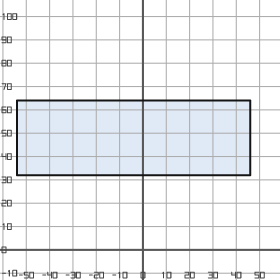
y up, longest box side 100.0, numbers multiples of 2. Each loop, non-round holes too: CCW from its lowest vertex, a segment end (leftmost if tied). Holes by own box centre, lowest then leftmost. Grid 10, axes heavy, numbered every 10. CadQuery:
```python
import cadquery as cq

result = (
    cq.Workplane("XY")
    .moveTo(-54.0, 32.0)
    .lineTo(46.0, 32.0)
    .lineTo(46.0, 64.0)
    .lineTo(-54.0, 64.0)
    .close()
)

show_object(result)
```